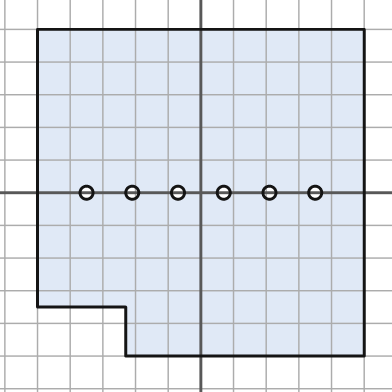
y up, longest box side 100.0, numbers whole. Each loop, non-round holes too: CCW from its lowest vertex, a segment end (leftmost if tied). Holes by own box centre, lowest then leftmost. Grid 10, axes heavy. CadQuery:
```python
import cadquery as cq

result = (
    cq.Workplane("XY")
    .moveTo(-23.0, -50.0)
    .lineTo(50.0, -50.0)
    .lineTo(50.0, 50.0)
    .lineTo(-50.0, 50.0)
    .lineTo(-50.0, -35.0)
    .lineTo(-23.0, -35.0)
    .close()
    .moveTo(-35.0, 0.0)
    .circle(2.0)
    .moveTo(-21.0, 0.0)
    .circle(2.0)
    .moveTo(-7.0, 0.0)
    .circle(2.0)
    .moveTo(7.0, 0.0)
    .circle(2.0)
    .moveTo(21.0, 0.0)
    .circle(2.0)
    .moveTo(35.0, 0.0)
    .circle(2.0)
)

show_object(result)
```